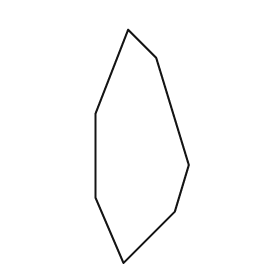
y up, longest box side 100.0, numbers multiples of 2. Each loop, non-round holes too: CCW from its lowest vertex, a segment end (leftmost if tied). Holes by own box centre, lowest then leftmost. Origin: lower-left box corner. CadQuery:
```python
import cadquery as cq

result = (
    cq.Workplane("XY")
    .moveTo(12.0, 0.0)
    .lineTo(34.0, 22.0)
    .lineTo(40.0, 42.0)
    .lineTo(26.0, 88.0)
    .lineTo(14.0, 100.0)
    .lineTo(0.0, 64.0)
    .lineTo(0.0, 28.0)
    .close()
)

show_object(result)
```